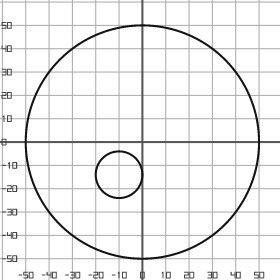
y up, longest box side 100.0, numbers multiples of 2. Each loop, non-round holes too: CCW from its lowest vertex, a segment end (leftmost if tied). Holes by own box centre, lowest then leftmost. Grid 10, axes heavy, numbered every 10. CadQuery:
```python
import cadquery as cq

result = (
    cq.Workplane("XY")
    .moveTo(0.0, 0.0)
    .circle(50.0)
    .moveTo(-10.0, -14.0)
    .circle(10.0)
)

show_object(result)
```